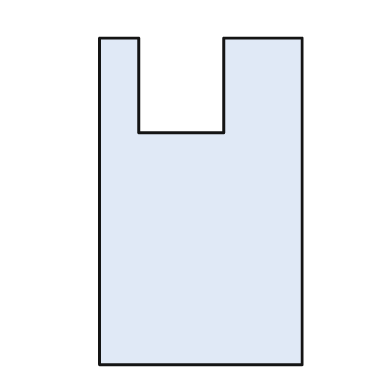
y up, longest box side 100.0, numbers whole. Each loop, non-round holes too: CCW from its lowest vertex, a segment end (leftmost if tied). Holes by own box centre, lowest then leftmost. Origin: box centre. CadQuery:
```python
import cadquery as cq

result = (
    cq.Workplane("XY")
    .moveTo(-31.0, -50.0)
    .lineTo(31.0, -50.0)
    .lineTo(31.0, 50.0)
    .lineTo(7.0, 50.0)
    .lineTo(7.0, 21.0)
    .lineTo(-19.0, 21.0)
    .lineTo(-19.0, 50.0)
    .lineTo(-31.0, 50.0)
    .close()
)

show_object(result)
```